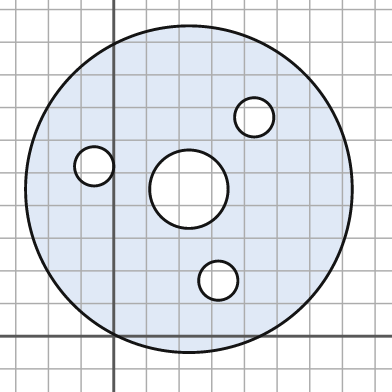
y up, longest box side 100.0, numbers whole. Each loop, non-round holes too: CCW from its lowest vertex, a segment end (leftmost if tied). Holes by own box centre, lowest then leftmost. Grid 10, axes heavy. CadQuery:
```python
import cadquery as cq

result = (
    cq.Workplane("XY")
    .moveTo(23.0, 45.0)
    .circle(50.0)
    .moveTo(32.0, 17.0)
    .circle(6.0)
    .moveTo(23.0, 45.0)
    .circle(12.0)
    .moveTo(-6.0, 52.0)
    .circle(6.0)
    .moveTo(43.0, 67.0)
    .circle(6.0)
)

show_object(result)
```